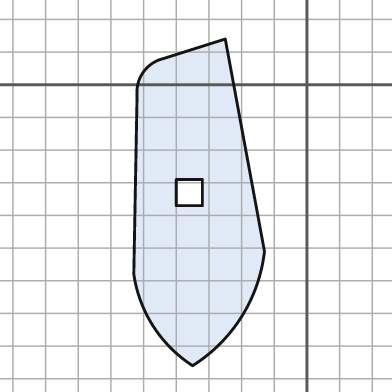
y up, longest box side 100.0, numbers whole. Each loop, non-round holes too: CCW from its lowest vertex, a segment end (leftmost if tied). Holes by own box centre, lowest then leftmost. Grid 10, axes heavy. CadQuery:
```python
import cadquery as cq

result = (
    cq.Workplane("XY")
    .moveTo(-35.0, -86.0)
    .threePointArc((-20.0, -71.0), (-13.0, -51.0))
    .lineTo(-25.0, 14.0)
    .lineTo(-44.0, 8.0)
    .threePointArc((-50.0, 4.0), (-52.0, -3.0))
    .lineTo(-53.0, -58.0)
    .threePointArc((-47.0, -74.0), (-35.0, -86.0))
    .close()
    .moveTo(-40.0, -37.0)
    .lineTo(-32.0, -37.0)
    .lineTo(-32.0, -29.0)
    .lineTo(-40.0, -29.0)
    .close()
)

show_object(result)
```